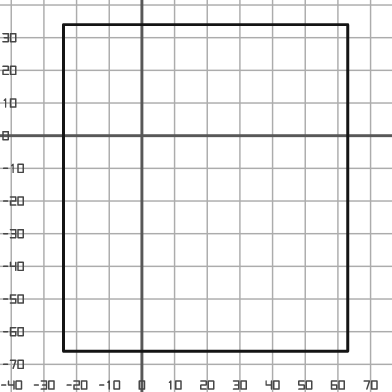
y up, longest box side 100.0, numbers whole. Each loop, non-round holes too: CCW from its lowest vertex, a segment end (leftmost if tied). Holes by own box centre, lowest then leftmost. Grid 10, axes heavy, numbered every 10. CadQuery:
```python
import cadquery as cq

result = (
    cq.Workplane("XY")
    .moveTo(-24.0, -66.0)
    .lineTo(63.0, -66.0)
    .lineTo(63.0, 34.0)
    .lineTo(-24.0, 34.0)
    .close()
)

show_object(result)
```